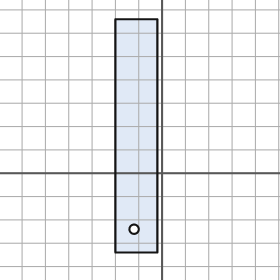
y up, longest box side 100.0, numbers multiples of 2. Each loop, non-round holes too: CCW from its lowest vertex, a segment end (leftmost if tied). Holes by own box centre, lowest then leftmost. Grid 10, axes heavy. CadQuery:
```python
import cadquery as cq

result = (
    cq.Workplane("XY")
    .moveTo(-20.0, -34.0)
    .lineTo(-2.0, -34.0)
    .lineTo(-2.0, 66.0)
    .lineTo(-20.0, 66.0)
    .close()
    .moveTo(-12.0, -24.0)
    .circle(2.0)
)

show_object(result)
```